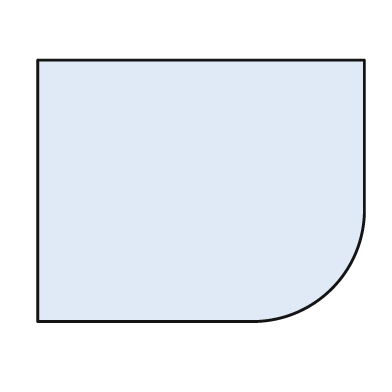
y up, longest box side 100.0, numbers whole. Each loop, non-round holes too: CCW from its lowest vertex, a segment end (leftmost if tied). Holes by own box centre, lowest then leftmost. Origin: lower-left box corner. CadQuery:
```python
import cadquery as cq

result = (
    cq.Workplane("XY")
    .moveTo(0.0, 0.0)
    .lineTo(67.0, 0.0)
    .threePointArc((90.0, 10.0), (100.0, 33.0))
    .lineTo(100.0, 80.0)
    .lineTo(0.0, 80.0)
    .close()
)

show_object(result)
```